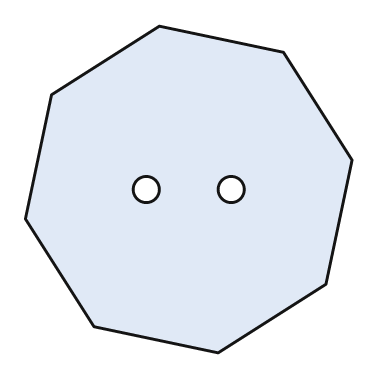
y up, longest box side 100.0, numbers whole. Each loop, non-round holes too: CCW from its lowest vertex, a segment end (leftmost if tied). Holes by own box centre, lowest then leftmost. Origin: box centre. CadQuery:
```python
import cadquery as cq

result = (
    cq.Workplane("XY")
    .moveTo(9.0, -50.0)
    .lineTo(42.0, -29.0)
    .lineTo(50.0, 9.0)
    .lineTo(29.0, 42.0)
    .lineTo(-9.0, 50.0)
    .lineTo(-42.0, 29.0)
    .lineTo(-50.0, -9.0)
    .lineTo(-29.0, -42.0)
    .close()
    .moveTo(-13.0, 0.0)
    .circle(4.0)
    .moveTo(13.0, 0.0)
    .circle(4.0)
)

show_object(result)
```